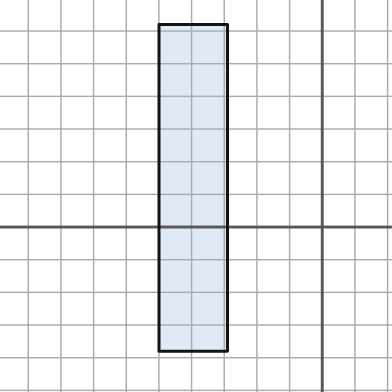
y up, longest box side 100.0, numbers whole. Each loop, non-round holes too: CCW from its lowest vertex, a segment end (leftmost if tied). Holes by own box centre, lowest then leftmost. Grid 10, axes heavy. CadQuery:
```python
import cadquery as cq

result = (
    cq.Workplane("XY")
    .moveTo(-50.0, -38.0)
    .lineTo(-29.0, -38.0)
    .lineTo(-29.0, 62.0)
    .lineTo(-50.0, 62.0)
    .close()
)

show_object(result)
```